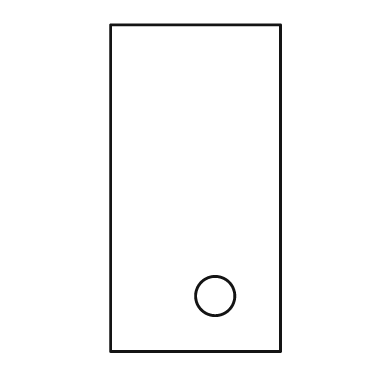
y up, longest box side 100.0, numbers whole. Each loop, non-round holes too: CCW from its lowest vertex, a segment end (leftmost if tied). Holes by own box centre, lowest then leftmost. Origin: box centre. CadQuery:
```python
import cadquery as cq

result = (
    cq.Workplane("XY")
    .moveTo(-26.0, -50.0)
    .lineTo(26.0, -50.0)
    .lineTo(26.0, 50.0)
    .lineTo(-26.0, 50.0)
    .close()
    .moveTo(6.0, -33.0)
    .circle(6.0)
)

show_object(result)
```